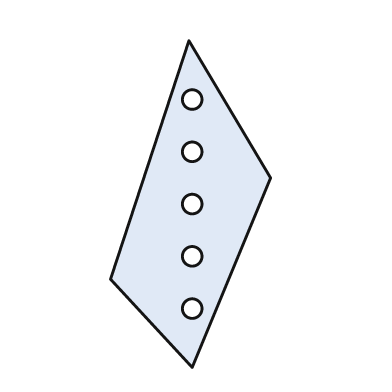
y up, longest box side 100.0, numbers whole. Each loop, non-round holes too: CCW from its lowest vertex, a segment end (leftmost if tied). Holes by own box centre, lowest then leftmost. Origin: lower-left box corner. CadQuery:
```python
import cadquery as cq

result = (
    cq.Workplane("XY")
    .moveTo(25.0, 0.0)
    .lineTo(49.0, 58.0)
    .lineTo(24.0, 100.0)
    .lineTo(0.0, 27.0)
    .close()
    .moveTo(25.0, 18.0)
    .circle(3.0)
    .moveTo(25.0, 34.0)
    .circle(3.0)
    .moveTo(25.0, 50.0)
    .circle(3.0)
    .moveTo(25.0, 66.0)
    .circle(3.0)
    .moveTo(25.0, 82.0)
    .circle(3.0)
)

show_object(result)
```